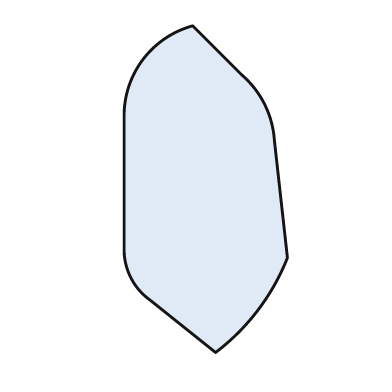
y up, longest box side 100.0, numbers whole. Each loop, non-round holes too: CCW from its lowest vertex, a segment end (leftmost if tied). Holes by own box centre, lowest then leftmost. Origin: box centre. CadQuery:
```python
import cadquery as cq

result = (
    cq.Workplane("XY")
    .moveTo(3.0, -50.0)
    .threePointArc((16.0, -37.0), (25.0, -21.0))
    .lineTo(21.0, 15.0)
    .threePointArc((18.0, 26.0), (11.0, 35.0))
    .lineTo(-4.0, 50.0)
    .threePointArc((-19.0, 40.0), (-25.0, 23.0))
    .lineTo(-25.0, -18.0)
    .threePointArc((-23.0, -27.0), (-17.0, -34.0))
    .close()
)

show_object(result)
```